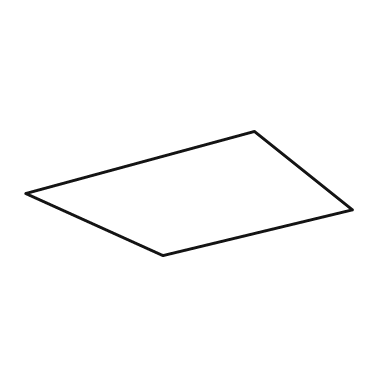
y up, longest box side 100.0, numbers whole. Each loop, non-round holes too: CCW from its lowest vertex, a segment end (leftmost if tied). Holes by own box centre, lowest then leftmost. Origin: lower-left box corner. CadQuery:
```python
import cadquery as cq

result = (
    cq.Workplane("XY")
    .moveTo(42.0, 0.0)
    .lineTo(100.0, 14.0)
    .lineTo(70.0, 38.0)
    .lineTo(0.0, 19.0)
    .close()
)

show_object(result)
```